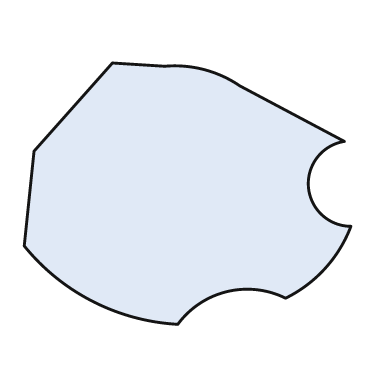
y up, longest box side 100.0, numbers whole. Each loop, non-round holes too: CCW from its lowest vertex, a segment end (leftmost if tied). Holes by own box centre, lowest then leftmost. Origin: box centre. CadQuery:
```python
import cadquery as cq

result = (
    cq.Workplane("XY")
    .moveTo(-3.0, -40.0)
    .threePointArc((12.0, -30.0), (30.0, -32.0))
    .threePointArc((42.0, -23.0), (50.0, -10.0))
    .threePointArc((37.0, 2.0), (48.0, 16.0))
    .lineTo(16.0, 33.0)
    .threePointArc((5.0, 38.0), (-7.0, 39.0))
    .lineTo(-23.0, 40.0)
    .lineTo(-47.0, 13.0)
    .lineTo(-50.0, -16.0)
    .threePointArc((-29.0, -33.0), (-3.0, -40.0))
    .close()
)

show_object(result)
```